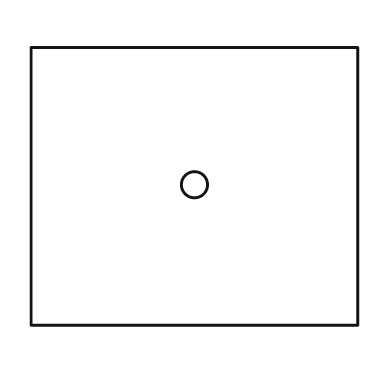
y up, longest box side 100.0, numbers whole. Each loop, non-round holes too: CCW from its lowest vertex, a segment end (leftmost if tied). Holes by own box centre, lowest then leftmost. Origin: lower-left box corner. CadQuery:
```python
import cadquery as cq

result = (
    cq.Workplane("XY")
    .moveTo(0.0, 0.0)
    .lineTo(100.0, 0.0)
    .lineTo(100.0, 85.0)
    .lineTo(0.0, 85.0)
    .close()
    .moveTo(50.0, 43.0)
    .circle(4.0)
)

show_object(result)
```